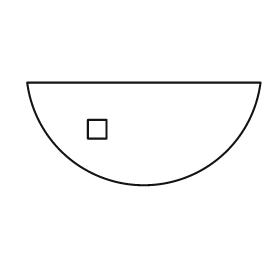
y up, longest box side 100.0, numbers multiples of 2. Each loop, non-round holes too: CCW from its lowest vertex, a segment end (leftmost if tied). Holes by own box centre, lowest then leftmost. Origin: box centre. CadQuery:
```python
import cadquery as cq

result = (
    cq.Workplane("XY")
    .moveTo(-50.0, 22.0)
    .threePointArc((0.0, -22.0), (50.0, 22.0))
    .close()
    .moveTo(-24.0, -2.0)
    .lineTo(-16.0, -2.0)
    .lineTo(-16.0, 6.0)
    .lineTo(-24.0, 6.0)
    .close()
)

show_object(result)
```